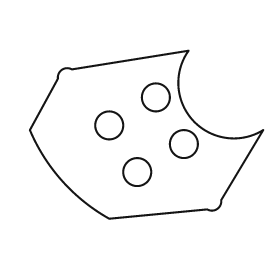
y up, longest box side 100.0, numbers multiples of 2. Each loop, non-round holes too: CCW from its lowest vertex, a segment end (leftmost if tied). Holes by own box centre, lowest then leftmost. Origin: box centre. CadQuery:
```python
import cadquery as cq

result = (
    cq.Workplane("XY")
    .moveTo(-16.0, -36.0)
    .lineTo(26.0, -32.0)
    .threePointArc((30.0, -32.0), (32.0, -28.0))
    .lineTo(50.0, 2.0)
    .threePointArc((20.0, 6.0), (18.0, 36.0))
    .lineTo(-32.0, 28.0)
    .threePointArc((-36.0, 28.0), (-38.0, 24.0))
    .lineTo(-50.0, 2.0)
    .threePointArc((-36.0, -20.0), (-16.0, -36.0))
    .close()
    .moveTo(-4.0, -16.0)
    .circle(6.0)
    .moveTo(16.0, -4.0)
    .circle(6.0)
    .moveTo(-16.0, 4.0)
    .circle(6.0)
    .moveTo(4.0, 16.0)
    .circle(6.0)
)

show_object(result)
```